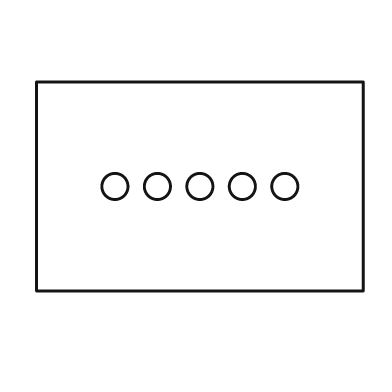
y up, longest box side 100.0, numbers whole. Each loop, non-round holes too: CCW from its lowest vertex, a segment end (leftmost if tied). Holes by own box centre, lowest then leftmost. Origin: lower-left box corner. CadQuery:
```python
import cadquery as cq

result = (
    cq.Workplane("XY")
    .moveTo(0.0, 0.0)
    .lineTo(100.0, 0.0)
    .lineTo(100.0, 64.0)
    .lineTo(0.0, 64.0)
    .close()
    .moveTo(24.0, 32.0)
    .circle(4.0)
    .moveTo(37.0, 32.0)
    .circle(4.0)
    .moveTo(50.0, 32.0)
    .circle(4.0)
    .moveTo(63.0, 32.0)
    .circle(4.0)
    .moveTo(76.0, 32.0)
    .circle(4.0)
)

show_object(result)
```